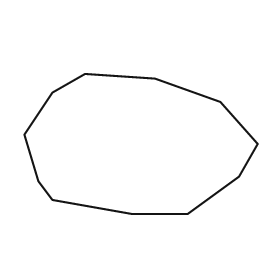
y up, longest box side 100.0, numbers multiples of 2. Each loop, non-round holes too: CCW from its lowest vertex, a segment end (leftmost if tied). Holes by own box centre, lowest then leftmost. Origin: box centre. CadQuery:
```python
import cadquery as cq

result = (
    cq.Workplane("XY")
    .moveTo(-4.0, -30.0)
    .lineTo(20.0, -30.0)
    .lineTo(42.0, -14.0)
    .lineTo(50.0, 0.0)
    .lineTo(34.0, 18.0)
    .lineTo(6.0, 28.0)
    .lineTo(-24.0, 30.0)
    .lineTo(-38.0, 22.0)
    .lineTo(-50.0, 4.0)
    .lineTo(-44.0, -16.0)
    .lineTo(-38.0, -24.0)
    .close()
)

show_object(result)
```